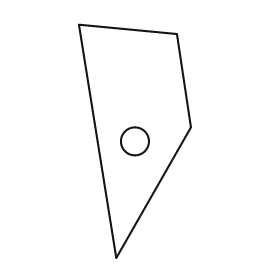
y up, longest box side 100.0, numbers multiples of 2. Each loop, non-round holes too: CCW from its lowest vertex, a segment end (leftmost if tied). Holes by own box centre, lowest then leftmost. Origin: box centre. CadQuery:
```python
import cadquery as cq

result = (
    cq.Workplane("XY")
    .moveTo(-8.0, -50.0)
    .lineTo(24.0, 6.0)
    .lineTo(18.0, 46.0)
    .lineTo(-24.0, 50.0)
    .close()
    .moveTo(0.0, 0.0)
    .circle(6.0)
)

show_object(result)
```